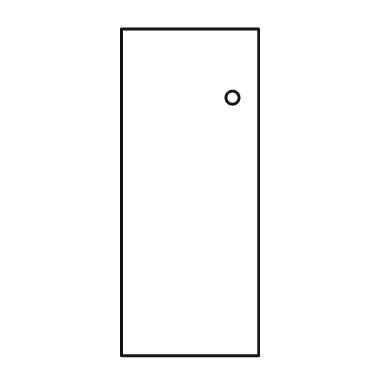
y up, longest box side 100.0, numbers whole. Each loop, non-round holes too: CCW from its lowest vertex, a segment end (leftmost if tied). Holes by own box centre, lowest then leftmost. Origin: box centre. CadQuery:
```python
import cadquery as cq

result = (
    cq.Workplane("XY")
    .moveTo(-21.0, -50.0)
    .lineTo(21.0, -50.0)
    .lineTo(21.0, 50.0)
    .lineTo(-21.0, 50.0)
    .close()
    .moveTo(13.0, 29.0)
    .circle(2.0)
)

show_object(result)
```